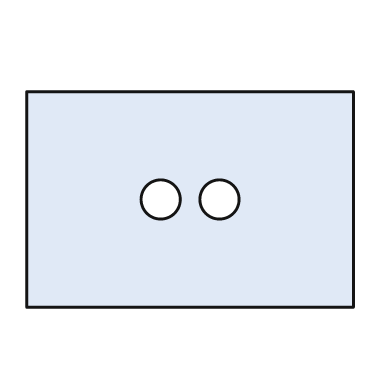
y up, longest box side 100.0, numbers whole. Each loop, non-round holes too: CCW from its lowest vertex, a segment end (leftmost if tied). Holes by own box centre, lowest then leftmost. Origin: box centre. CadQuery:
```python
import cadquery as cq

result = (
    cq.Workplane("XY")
    .moveTo(-50.0, -33.0)
    .lineTo(50.0, -33.0)
    .lineTo(50.0, 33.0)
    .lineTo(-50.0, 33.0)
    .close()
    .moveTo(-9.0, 0.0)
    .circle(6.0)
    .moveTo(9.0, 0.0)
    .circle(6.0)
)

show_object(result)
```